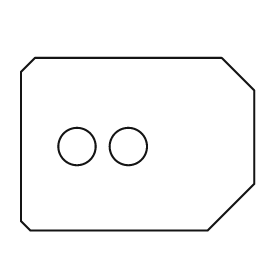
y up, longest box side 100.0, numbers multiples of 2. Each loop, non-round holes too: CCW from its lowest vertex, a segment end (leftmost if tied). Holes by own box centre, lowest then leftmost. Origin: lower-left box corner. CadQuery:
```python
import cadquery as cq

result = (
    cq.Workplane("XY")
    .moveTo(4.0, 0.0)
    .lineTo(80.0, 0.0)
    .lineTo(100.0, 20.0)
    .lineTo(100.0, 60.0)
    .lineTo(86.0, 74.0)
    .lineTo(6.0, 74.0)
    .lineTo(0.0, 68.0)
    .lineTo(0.0, 4.0)
    .close()
    .moveTo(24.0, 36.0)
    .circle(8.0)
    .moveTo(46.0, 36.0)
    .circle(8.0)
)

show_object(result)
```